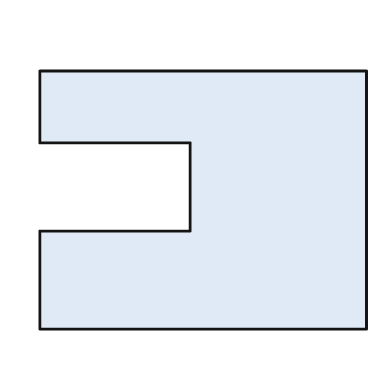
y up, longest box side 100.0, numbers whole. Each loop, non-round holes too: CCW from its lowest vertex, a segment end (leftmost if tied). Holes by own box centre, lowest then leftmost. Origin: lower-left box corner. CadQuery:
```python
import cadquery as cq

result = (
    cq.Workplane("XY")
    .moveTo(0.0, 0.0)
    .lineTo(100.0, 0.0)
    .lineTo(100.0, 79.0)
    .lineTo(0.0, 79.0)
    .lineTo(0.0, 57.0)
    .lineTo(46.0, 57.0)
    .lineTo(46.0, 30.0)
    .lineTo(0.0, 30.0)
    .close()
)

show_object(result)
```